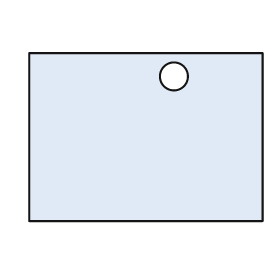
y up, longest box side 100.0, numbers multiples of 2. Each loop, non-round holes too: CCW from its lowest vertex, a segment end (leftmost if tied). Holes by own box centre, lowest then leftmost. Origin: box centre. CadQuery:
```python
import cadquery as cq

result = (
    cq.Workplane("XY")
    .moveTo(-50.0, -36.0)
    .lineTo(50.0, -36.0)
    .lineTo(50.0, 36.0)
    .lineTo(-50.0, 36.0)
    .close()
    .moveTo(12.0, 26.0)
    .circle(6.0)
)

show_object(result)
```